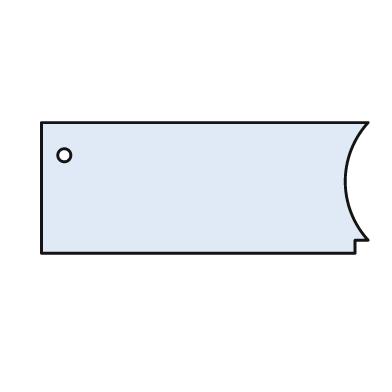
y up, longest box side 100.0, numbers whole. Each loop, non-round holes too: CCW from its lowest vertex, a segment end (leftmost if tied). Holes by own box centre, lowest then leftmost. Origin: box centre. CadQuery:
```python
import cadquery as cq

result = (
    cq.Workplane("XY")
    .moveTo(-50.0, -20.0)
    .lineTo(46.0, -20.0)
    .lineTo(46.0, -16.0)
    .lineTo(50.0, -16.0)
    .threePointArc((43.0, 2.0), (50.0, 20.0))
    .lineTo(-50.0, 20.0)
    .close()
    .moveTo(-43.0, 10.0)
    .circle(2.0)
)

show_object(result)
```